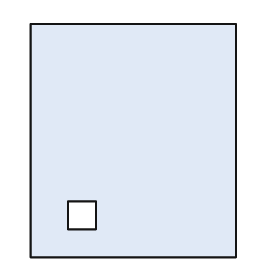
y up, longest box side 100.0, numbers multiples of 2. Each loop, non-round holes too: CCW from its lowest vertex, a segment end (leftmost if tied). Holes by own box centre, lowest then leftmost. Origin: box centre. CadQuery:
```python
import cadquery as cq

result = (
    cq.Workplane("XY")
    .moveTo(-44.0, -50.0)
    .lineTo(44.0, -50.0)
    .lineTo(44.0, 50.0)
    .lineTo(-44.0, 50.0)
    .close()
    .moveTo(-28.0, -38.0)
    .lineTo(-16.0, -38.0)
    .lineTo(-16.0, -26.0)
    .lineTo(-28.0, -26.0)
    .close()
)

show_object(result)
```